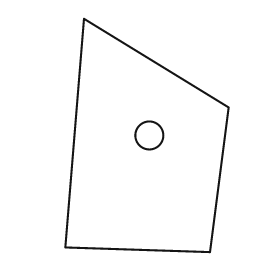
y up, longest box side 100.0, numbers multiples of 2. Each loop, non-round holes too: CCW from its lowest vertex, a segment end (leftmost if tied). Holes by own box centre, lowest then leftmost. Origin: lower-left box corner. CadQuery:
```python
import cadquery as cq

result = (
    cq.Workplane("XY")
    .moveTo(62.0, 0.0)
    .lineTo(70.0, 62.0)
    .lineTo(8.0, 100.0)
    .lineTo(0.0, 2.0)
    .close()
    .moveTo(36.0, 50.0)
    .circle(6.0)
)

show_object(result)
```